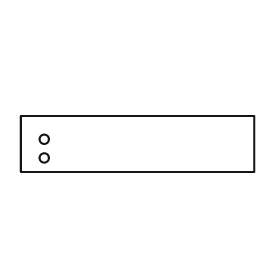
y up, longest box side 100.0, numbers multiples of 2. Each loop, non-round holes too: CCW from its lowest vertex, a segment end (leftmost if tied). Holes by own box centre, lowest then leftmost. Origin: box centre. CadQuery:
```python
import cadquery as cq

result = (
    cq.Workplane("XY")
    .moveTo(-50.0, -12.0)
    .lineTo(50.0, -12.0)
    .lineTo(50.0, 12.0)
    .lineTo(-50.0, 12.0)
    .close()
    .moveTo(-40.0, -6.0)
    .circle(2.0)
    .moveTo(-40.0, 2.0)
    .circle(2.0)
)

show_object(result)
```